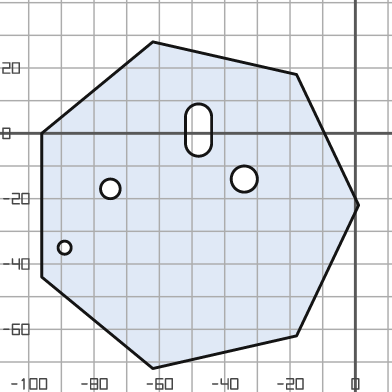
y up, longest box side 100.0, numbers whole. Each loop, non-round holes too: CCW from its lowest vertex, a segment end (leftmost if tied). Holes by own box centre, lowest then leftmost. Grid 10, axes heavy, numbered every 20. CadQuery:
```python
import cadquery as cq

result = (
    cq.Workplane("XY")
    .moveTo(-62.0, -72.0)
    .lineTo(-18.0, -62.0)
    .lineTo(1.0, -22.0)
    .lineTo(-18.0, 18.0)
    .lineTo(-62.0, 28.0)
    .lineTo(-96.0, 0.0)
    .lineTo(-96.0, -44.0)
    .close()
    .moveTo(-89.0, -35.0)
    .circle(2.0)
    .moveTo(-75.0, -17.0)
    .circle(3.0)
    .moveTo(-34.0, -14.0)
    .circle(4.0)
    .moveTo(-52.0, -3.0)
    .threePointArc((-48.0, -7.0), (-44.0, -3.0))
    .lineTo(-44.0, 5.0)
    .threePointArc((-48.0, 9.0), (-52.0, 5.0))
    .close()
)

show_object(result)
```